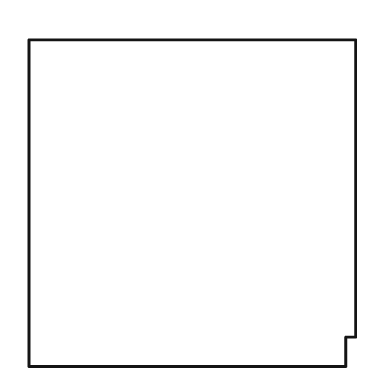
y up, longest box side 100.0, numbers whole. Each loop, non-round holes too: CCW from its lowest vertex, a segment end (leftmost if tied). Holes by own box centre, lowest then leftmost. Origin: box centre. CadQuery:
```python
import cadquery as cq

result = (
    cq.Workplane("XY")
    .moveTo(-50.0, -50.0)
    .lineTo(47.0, -50.0)
    .lineTo(47.0, -41.0)
    .lineTo(50.0, -41.0)
    .lineTo(50.0, 50.0)
    .lineTo(-50.0, 50.0)
    .close()
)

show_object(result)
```